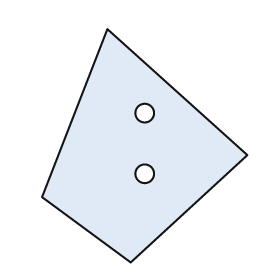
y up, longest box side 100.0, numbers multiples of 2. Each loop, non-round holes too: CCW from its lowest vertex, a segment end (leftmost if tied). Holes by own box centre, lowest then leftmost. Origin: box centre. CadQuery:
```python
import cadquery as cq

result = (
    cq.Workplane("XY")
    .moveTo(-6.0, -50.0)
    .lineTo(44.0, -4.0)
    .lineTo(-16.0, 50.0)
    .lineTo(-44.0, -22.0)
    .close()
    .moveTo(0.0, -12.0)
    .circle(4.0)
    .moveTo(0.0, 14.0)
    .circle(4.0)
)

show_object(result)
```